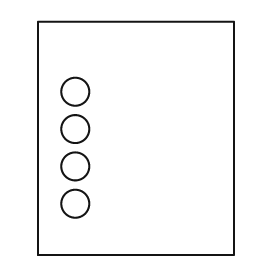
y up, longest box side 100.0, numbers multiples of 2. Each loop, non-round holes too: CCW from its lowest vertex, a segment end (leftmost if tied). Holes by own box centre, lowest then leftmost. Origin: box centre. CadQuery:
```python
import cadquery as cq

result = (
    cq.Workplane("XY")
    .moveTo(-42.0, -50.0)
    .lineTo(42.0, -50.0)
    .lineTo(42.0, 50.0)
    .lineTo(-42.0, 50.0)
    .close()
    .moveTo(-26.0, -28.0)
    .circle(6.0)
    .moveTo(-26.0, -12.0)
    .circle(6.0)
    .moveTo(-26.0, 4.0)
    .circle(6.0)
    .moveTo(-26.0, 20.0)
    .circle(6.0)
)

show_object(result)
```